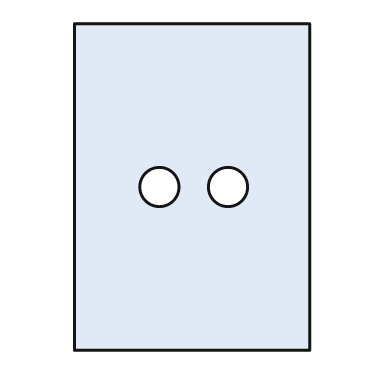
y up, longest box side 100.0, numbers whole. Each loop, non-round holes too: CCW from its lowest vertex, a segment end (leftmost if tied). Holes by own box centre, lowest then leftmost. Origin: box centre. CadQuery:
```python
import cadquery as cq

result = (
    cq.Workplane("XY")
    .moveTo(-36.0, -50.0)
    .lineTo(36.0, -50.0)
    .lineTo(36.0, 50.0)
    .lineTo(-36.0, 50.0)
    .close()
    .moveTo(-10.0, 0.0)
    .circle(6.0)
    .moveTo(11.0, 0.0)
    .circle(6.0)
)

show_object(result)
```